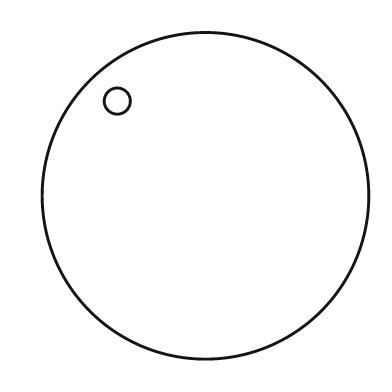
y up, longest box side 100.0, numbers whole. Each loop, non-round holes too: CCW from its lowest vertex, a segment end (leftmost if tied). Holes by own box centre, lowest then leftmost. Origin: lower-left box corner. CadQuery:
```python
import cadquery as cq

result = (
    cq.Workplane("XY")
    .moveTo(50.0, 50.0)
    .circle(50.0)
    .moveTo(23.0, 79.0)
    .circle(4.0)
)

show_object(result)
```